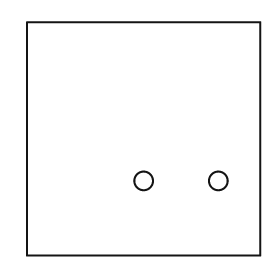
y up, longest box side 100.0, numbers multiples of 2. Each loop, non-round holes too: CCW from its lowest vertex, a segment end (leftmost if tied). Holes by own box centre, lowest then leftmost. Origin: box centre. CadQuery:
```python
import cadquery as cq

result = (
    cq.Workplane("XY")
    .moveTo(-50.0, -50.0)
    .lineTo(50.0, -50.0)
    .lineTo(50.0, 50.0)
    .lineTo(-50.0, 50.0)
    .close()
    .moveTo(0.0, -18.0)
    .circle(4.0)
    .moveTo(32.0, -18.0)
    .circle(4.0)
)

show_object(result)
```